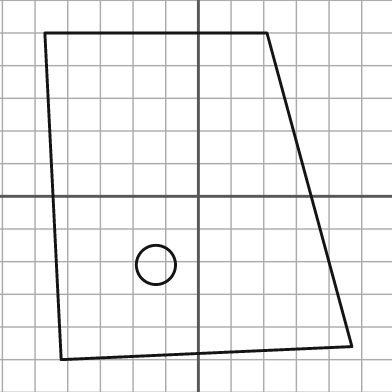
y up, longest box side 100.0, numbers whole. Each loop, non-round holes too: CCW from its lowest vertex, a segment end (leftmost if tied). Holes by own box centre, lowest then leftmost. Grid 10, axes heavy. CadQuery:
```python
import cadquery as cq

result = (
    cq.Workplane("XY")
    .moveTo(-42.0, -50.0)
    .lineTo(47.0, -46.0)
    .lineTo(21.0, 50.0)
    .lineTo(-47.0, 50.0)
    .close()
    .moveTo(-13.0, -21.0)
    .circle(6.0)
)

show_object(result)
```